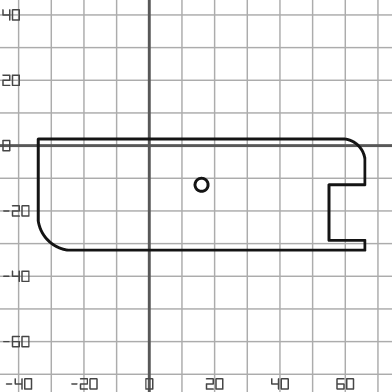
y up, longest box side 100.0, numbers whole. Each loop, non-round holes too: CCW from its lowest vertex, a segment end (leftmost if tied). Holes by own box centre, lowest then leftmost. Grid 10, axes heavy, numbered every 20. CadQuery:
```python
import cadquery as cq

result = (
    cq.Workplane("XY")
    .moveTo(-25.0, -32.0)
    .lineTo(66.0, -32.0)
    .lineTo(66.0, -29.0)
    .lineTo(55.0, -29.0)
    .lineTo(55.0, -12.0)
    .lineTo(66.0, -12.0)
    .lineTo(66.0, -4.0)
    .threePointArc((64.0, 0.0), (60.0, 2.0))
    .lineTo(-34.0, 2.0)
    .lineTo(-34.0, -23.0)
    .threePointArc((-31.0, -29.0), (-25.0, -32.0))
    .close()
    .moveTo(16.0, -12.0)
    .circle(2.0)
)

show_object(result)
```